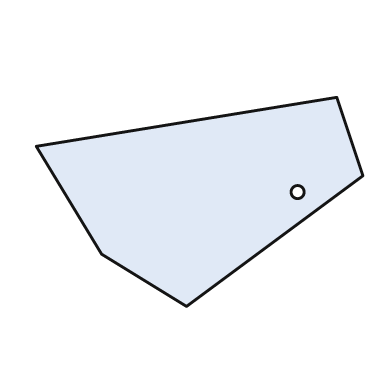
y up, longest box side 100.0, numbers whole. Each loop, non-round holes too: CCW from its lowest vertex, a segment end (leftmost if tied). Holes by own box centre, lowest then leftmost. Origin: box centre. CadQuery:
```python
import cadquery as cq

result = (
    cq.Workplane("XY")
    .moveTo(-4.0, -32.0)
    .lineTo(50.0, 8.0)
    .lineTo(42.0, 32.0)
    .lineTo(-50.0, 17.0)
    .lineTo(-30.0, -16.0)
    .close()
    .moveTo(30.0, 3.0)
    .circle(2.0)
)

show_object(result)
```